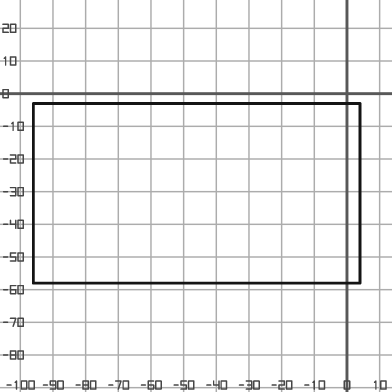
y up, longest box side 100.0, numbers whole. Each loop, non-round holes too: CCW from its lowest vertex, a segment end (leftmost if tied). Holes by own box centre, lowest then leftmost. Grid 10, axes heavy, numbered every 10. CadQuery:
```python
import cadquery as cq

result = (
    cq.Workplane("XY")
    .moveTo(-96.0, -58.0)
    .lineTo(4.0, -58.0)
    .lineTo(4.0, -3.0)
    .lineTo(-96.0, -3.0)
    .close()
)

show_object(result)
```